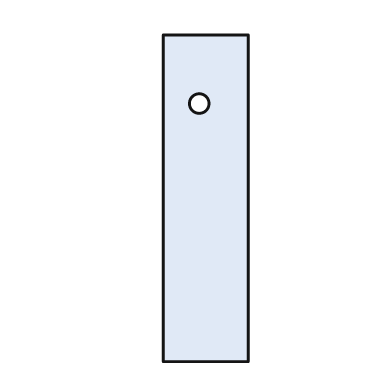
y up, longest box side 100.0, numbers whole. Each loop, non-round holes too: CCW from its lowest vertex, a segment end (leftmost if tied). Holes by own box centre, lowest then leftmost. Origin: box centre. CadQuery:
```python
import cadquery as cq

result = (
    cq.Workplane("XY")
    .moveTo(-13.0, -50.0)
    .lineTo(13.0, -50.0)
    .lineTo(13.0, 50.0)
    .lineTo(-13.0, 50.0)
    .close()
    .moveTo(-2.0, 29.0)
    .circle(3.0)
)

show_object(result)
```